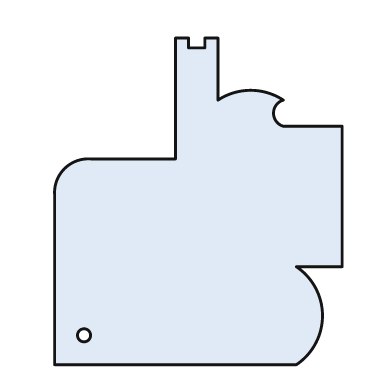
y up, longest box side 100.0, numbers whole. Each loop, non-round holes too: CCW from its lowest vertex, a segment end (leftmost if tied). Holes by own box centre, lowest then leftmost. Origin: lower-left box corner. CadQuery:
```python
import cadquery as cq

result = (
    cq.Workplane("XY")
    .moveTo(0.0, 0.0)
    .lineTo(74.0, 0.0)
    .threePointArc((82.0, 15.0), (74.0, 30.0))
    .lineTo(88.0, 30.0)
    .lineTo(88.0, 73.0)
    .lineTo(70.0, 73.0)
    .threePointArc((67.0, 77.0), (70.0, 81.0))
    .threePointArc((60.0, 84.0), (50.0, 81.0))
    .lineTo(50.0, 100.0)
    .lineTo(46.0, 100.0)
    .lineTo(46.0, 97.0)
    .lineTo(41.0, 97.0)
    .lineTo(41.0, 100.0)
    .lineTo(37.0, 100.0)
    .lineTo(37.0, 63.0)
    .lineTo(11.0, 63.0)
    .threePointArc((3.0, 60.0), (0.0, 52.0))
    .close()
    .moveTo(9.0, 9.0)
    .circle(2.0)
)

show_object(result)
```